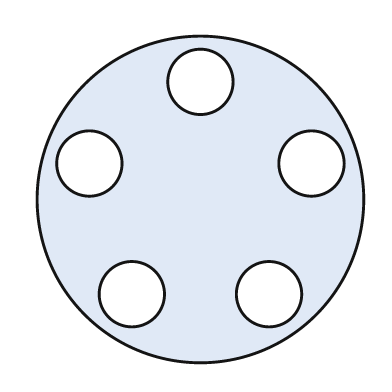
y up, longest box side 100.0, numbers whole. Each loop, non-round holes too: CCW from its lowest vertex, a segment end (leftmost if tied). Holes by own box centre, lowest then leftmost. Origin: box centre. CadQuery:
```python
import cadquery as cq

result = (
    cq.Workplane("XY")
    .moveTo(0.0, 0.0)
    .circle(50.0)
    .moveTo(-21.0, -29.0)
    .circle(10.0)
    .moveTo(21.0, -29.0)
    .circle(10.0)
    .moveTo(-34.0, 11.0)
    .circle(10.0)
    .moveTo(34.0, 11.0)
    .circle(10.0)
    .moveTo(0.0, 36.0)
    .circle(10.0)
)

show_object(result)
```